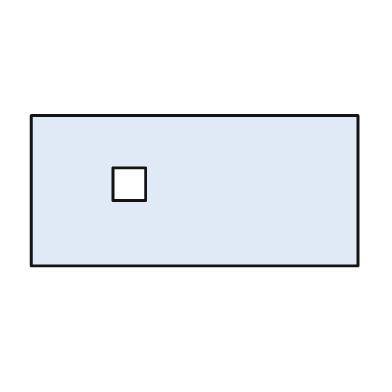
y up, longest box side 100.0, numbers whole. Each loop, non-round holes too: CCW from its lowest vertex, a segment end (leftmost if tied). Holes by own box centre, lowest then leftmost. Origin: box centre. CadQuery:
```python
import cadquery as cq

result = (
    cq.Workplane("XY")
    .moveTo(-50.0, -23.0)
    .lineTo(50.0, -23.0)
    .lineTo(50.0, 23.0)
    .lineTo(-50.0, 23.0)
    .close()
    .moveTo(-25.0, -3.0)
    .lineTo(-15.0, -3.0)
    .lineTo(-15.0, 7.0)
    .lineTo(-25.0, 7.0)
    .close()
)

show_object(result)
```